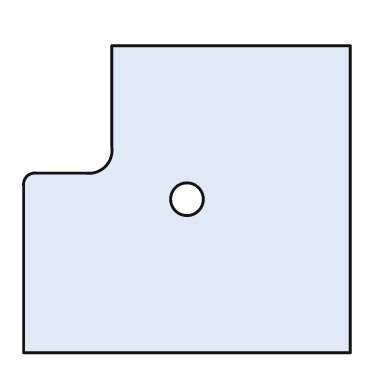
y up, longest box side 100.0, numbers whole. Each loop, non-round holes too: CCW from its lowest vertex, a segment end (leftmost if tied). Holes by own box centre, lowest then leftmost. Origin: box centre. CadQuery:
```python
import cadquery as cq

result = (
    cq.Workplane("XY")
    .moveTo(-50.0, -47.0)
    .lineTo(50.0, -47.0)
    .lineTo(50.0, 47.0)
    .lineTo(-23.0, 47.0)
    .lineTo(-23.0, 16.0)
    .threePointArc((-25.0, 10.0), (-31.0, 8.0))
    .lineTo(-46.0, 8.0)
    .threePointArc((-49.0, 7.0), (-50.0, 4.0))
    .close()
    .moveTo(0.0, 0.0)
    .circle(5.0)
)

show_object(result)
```